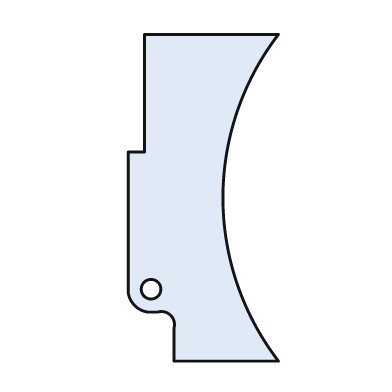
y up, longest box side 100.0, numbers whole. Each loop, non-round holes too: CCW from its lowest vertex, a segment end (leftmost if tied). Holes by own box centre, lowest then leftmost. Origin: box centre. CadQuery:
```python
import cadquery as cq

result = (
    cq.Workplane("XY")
    .moveTo(-9.0, -50.0)
    .lineTo(23.0, -50.0)
    .threePointArc((6.0, 0.0), (23.0, 50.0))
    .lineTo(-18.0, 50.0)
    .lineTo(-18.0, 14.0)
    .lineTo(-23.0, 14.0)
    .lineTo(-23.0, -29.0)
    .threePointArc((-21.0, -33.0), (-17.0, -35.0))
    .lineTo(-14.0, -35.0)
    .threePointArc((-10.0, -36.0), (-9.0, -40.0))
    .close()
    .moveTo(-16.0, -28.0)
    .circle(3.0)
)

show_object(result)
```